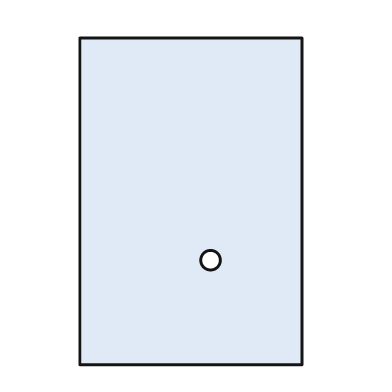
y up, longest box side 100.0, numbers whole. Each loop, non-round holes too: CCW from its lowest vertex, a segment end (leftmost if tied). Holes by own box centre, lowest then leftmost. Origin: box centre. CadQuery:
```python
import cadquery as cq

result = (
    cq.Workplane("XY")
    .moveTo(-34.0, -50.0)
    .lineTo(34.0, -50.0)
    .lineTo(34.0, 50.0)
    .lineTo(-34.0, 50.0)
    .close()
    .moveTo(6.0, -18.0)
    .circle(3.0)
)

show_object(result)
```